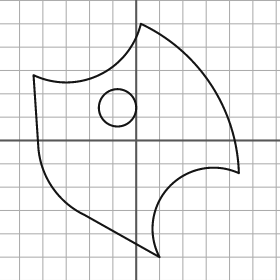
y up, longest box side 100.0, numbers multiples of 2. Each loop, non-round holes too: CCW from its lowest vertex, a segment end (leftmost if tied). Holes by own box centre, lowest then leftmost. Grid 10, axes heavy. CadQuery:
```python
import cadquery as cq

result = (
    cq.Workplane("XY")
    .moveTo(10.0, -50.0)
    .threePointArc((14.0, -20.0), (44.0, -14.0))
    .threePointArc((32.0, 24.0), (2.0, 50.0))
    .threePointArc((-16.0, 28.0), (-44.0, 28.0))
    .lineTo(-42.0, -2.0)
    .threePointArc((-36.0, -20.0), (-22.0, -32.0))
    .close()
    .moveTo(-8.0, 14.0)
    .circle(8.0)
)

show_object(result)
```